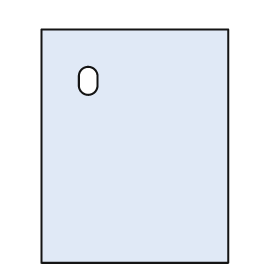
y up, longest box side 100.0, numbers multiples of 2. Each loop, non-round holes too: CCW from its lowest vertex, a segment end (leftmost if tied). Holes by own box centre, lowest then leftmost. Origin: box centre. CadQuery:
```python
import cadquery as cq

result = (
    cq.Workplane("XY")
    .moveTo(-40.0, -50.0)
    .lineTo(40.0, -50.0)
    .lineTo(40.0, 50.0)
    .lineTo(-40.0, 50.0)
    .close()
    .moveTo(-24.0, 26.0)
    .threePointArc((-20.0, 22.0), (-16.0, 26.0))
    .lineTo(-16.0, 30.0)
    .threePointArc((-20.0, 34.0), (-24.0, 30.0))
    .close()
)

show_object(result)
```